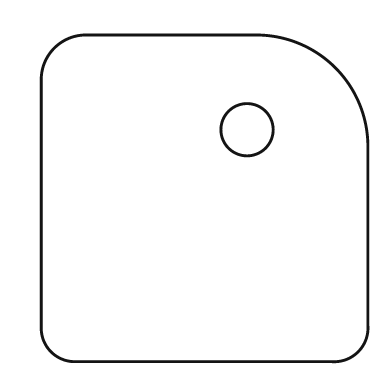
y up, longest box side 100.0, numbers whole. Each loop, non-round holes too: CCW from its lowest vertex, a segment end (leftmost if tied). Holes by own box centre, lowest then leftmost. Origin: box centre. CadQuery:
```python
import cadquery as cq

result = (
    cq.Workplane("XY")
    .moveTo(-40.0, -50.0)
    .lineTo(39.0, -50.0)
    .threePointArc((47.0, -47.0), (50.0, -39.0))
    .lineTo(50.0, 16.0)
    .threePointArc((40.0, 40.0), (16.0, 50.0))
    .lineTo(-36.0, 50.0)
    .threePointArc((-46.0, 46.0), (-50.0, 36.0))
    .lineTo(-50.0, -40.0)
    .threePointArc((-47.0, -47.0), (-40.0, -50.0))
    .close()
    .moveTo(13.0, 21.0)
    .circle(8.0)
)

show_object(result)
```